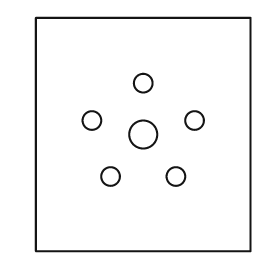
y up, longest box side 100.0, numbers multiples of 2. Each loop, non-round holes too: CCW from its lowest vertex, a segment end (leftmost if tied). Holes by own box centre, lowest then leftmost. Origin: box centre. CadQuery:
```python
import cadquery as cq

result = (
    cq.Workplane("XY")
    .moveTo(-46.0, -50.0)
    .lineTo(46.0, -50.0)
    .lineTo(46.0, 50.0)
    .lineTo(-46.0, 50.0)
    .close()
    .moveTo(-14.0, -18.0)
    .circle(4.0)
    .moveTo(14.0, -18.0)
    .circle(4.0)
    .moveTo(0.0, 0.0)
    .circle(6.0)
    .moveTo(-22.0, 6.0)
    .circle(4.0)
    .moveTo(22.0, 6.0)
    .circle(4.0)
    .moveTo(0.0, 22.0)
    .circle(4.0)
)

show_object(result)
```